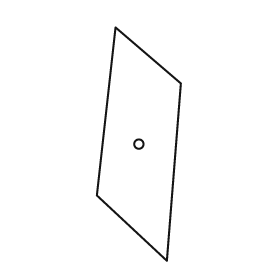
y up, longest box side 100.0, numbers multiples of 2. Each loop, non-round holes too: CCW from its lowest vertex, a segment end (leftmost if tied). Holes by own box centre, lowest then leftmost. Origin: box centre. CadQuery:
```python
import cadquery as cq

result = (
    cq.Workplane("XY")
    .moveTo(12.0, -50.0)
    .lineTo(18.0, 26.0)
    .lineTo(-10.0, 50.0)
    .lineTo(-18.0, -22.0)
    .close()
    .moveTo(0.0, 0.0)
    .circle(2.0)
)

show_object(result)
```